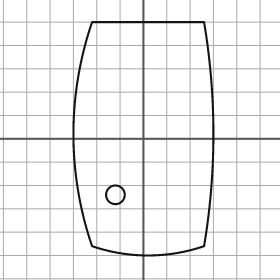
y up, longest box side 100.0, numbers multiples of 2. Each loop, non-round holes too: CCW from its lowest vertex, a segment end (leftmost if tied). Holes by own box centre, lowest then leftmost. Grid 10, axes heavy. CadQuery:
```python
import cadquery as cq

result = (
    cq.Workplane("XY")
    .moveTo(-22.0, -46.0)
    .threePointArc((2.0, -50.0), (26.0, -46.0))
    .threePointArc((30.0, 2.0), (26.0, 50.0))
    .lineTo(-22.0, 50.0)
    .threePointArc((-30.0, 2.0), (-22.0, -46.0))
    .close()
    .moveTo(-12.0, -24.0)
    .circle(4.0)
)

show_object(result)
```